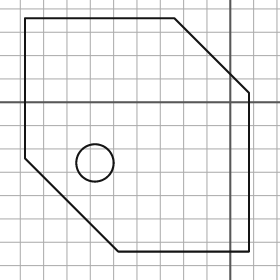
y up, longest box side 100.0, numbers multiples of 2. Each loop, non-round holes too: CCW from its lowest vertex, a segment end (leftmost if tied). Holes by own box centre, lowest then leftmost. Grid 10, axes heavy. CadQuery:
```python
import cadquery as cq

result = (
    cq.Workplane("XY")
    .moveTo(-48.0, -64.0)
    .lineTo(8.0, -64.0)
    .lineTo(8.0, 4.0)
    .lineTo(-24.0, 36.0)
    .lineTo(-88.0, 36.0)
    .lineTo(-88.0, -24.0)
    .close()
    .moveTo(-58.0, -26.0)
    .circle(8.0)
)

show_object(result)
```